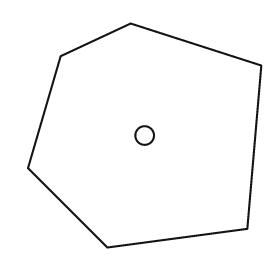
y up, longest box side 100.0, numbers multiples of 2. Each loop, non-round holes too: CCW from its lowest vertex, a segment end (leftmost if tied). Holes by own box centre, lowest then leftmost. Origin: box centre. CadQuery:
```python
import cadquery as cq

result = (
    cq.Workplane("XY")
    .moveTo(-16.0, -48.0)
    .lineTo(44.0, -40.0)
    .lineTo(50.0, 30.0)
    .lineTo(-6.0, 48.0)
    .lineTo(-36.0, 34.0)
    .lineTo(-50.0, -14.0)
    .close()
    .moveTo(0.0, 0.0)
    .circle(4.0)
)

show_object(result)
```